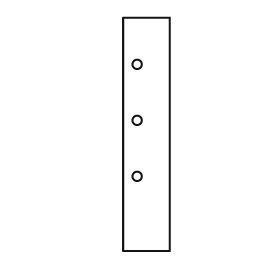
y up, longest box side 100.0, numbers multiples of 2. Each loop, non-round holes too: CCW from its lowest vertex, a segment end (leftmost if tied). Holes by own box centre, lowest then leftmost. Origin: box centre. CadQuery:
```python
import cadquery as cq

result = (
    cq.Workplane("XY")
    .moveTo(-10.0, -50.0)
    .lineTo(10.0, -50.0)
    .lineTo(10.0, 50.0)
    .lineTo(-10.0, 50.0)
    .close()
    .moveTo(-4.0, -18.0)
    .circle(2.0)
    .moveTo(-4.0, 6.0)
    .circle(2.0)
    .moveTo(-4.0, 30.0)
    .circle(2.0)
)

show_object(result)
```